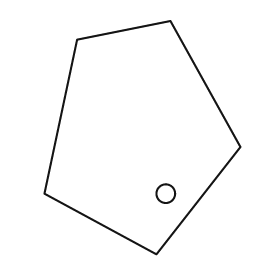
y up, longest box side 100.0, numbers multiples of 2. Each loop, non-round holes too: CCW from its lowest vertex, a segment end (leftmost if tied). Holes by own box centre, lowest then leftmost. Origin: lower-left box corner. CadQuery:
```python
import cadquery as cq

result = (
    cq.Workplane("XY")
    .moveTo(48.0, 0.0)
    .lineTo(84.0, 46.0)
    .lineTo(54.0, 100.0)
    .lineTo(14.0, 92.0)
    .lineTo(0.0, 26.0)
    .close()
    .moveTo(52.0, 26.0)
    .circle(4.0)
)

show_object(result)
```